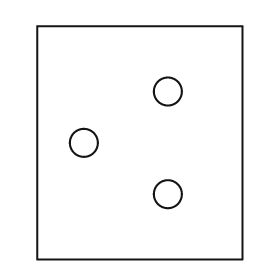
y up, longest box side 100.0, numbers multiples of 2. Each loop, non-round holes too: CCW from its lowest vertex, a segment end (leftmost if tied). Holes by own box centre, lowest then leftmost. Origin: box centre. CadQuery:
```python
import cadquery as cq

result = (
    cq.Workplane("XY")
    .moveTo(-44.0, -50.0)
    .lineTo(44.0, -50.0)
    .lineTo(44.0, 50.0)
    .lineTo(-44.0, 50.0)
    .close()
    .moveTo(12.0, -22.0)
    .circle(6.0)
    .moveTo(-24.0, 0.0)
    .circle(6.0)
    .moveTo(12.0, 22.0)
    .circle(6.0)
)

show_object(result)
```